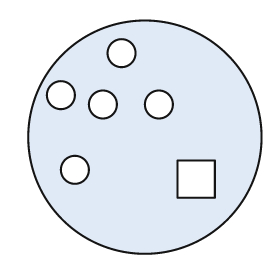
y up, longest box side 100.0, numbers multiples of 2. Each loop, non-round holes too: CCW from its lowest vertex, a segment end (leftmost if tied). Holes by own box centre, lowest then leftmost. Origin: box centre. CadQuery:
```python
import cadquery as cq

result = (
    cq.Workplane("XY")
    .moveTo(0.0, 0.0)
    .circle(50.0)
    .moveTo(14.0, -26.0)
    .lineTo(30.0, -26.0)
    .lineTo(30.0, -10.0)
    .lineTo(14.0, -10.0)
    .close()
    .moveTo(-30.0, -14.0)
    .circle(6.0)
    .moveTo(-18.0, 14.0)
    .circle(6.0)
    .moveTo(6.0, 14.0)
    .circle(6.0)
    .moveTo(-36.0, 18.0)
    .circle(6.0)
    .moveTo(-10.0, 36.0)
    .circle(6.0)
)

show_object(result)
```